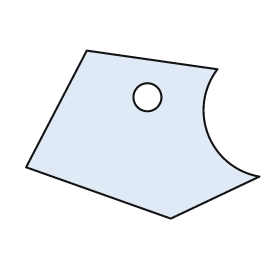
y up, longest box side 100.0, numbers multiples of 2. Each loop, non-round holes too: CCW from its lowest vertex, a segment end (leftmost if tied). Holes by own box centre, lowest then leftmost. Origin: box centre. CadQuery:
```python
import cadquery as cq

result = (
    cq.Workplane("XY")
    .moveTo(12.0, -36.0)
    .lineTo(50.0, -18.0)
    .threePointArc((28.0, 0.0), (32.0, 28.0))
    .lineTo(-24.0, 36.0)
    .lineTo(-50.0, -14.0)
    .close()
    .moveTo(2.0, 16.0)
    .circle(6.0)
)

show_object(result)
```